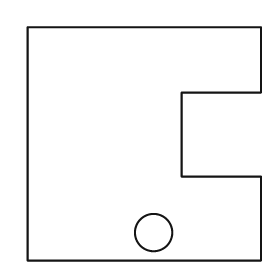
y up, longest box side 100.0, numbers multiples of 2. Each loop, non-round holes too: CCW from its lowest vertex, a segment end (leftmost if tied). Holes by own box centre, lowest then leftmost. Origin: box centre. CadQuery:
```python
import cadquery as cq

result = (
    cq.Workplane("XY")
    .moveTo(-50.0, -50.0)
    .lineTo(50.0, -50.0)
    .lineTo(50.0, -14.0)
    .lineTo(16.0, -14.0)
    .lineTo(16.0, 22.0)
    .lineTo(50.0, 22.0)
    .lineTo(50.0, 50.0)
    .lineTo(-50.0, 50.0)
    .close()
    .moveTo(4.0, -38.0)
    .circle(8.0)
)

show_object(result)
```